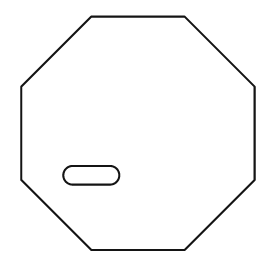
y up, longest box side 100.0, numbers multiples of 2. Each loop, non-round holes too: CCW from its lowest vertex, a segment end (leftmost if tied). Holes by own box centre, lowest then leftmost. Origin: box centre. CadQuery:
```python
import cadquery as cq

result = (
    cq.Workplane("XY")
    .moveTo(-20.0, -50.0)
    .lineTo(20.0, -50.0)
    .lineTo(50.0, -20.0)
    .lineTo(50.0, 20.0)
    .lineTo(20.0, 50.0)
    .lineTo(-20.0, 50.0)
    .lineTo(-50.0, 20.0)
    .lineTo(-50.0, -20.0)
    .close()
    .moveTo(-28.0, -22.0)
    .lineTo(-12.0, -22.0)
    .threePointArc((-8.0, -18.0), (-12.0, -14.0))
    .lineTo(-28.0, -14.0)
    .threePointArc((-32.0, -18.0), (-28.0, -22.0))
    .close()
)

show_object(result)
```